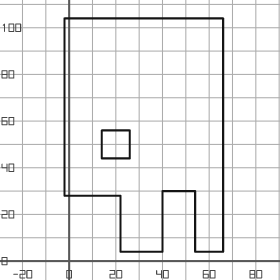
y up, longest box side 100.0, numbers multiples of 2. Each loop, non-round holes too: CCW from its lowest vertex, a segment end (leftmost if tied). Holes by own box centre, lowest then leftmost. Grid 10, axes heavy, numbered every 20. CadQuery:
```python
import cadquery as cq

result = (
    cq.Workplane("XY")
    .moveTo(22.0, 4.0)
    .lineTo(40.0, 4.0)
    .lineTo(40.0, 30.0)
    .lineTo(54.0, 30.0)
    .lineTo(54.0, 4.0)
    .lineTo(66.0, 4.0)
    .lineTo(66.0, 104.0)
    .lineTo(-2.0, 104.0)
    .lineTo(-2.0, 28.0)
    .lineTo(22.0, 28.0)
    .close()
    .moveTo(14.0, 44.0)
    .lineTo(26.0, 44.0)
    .lineTo(26.0, 56.0)
    .lineTo(14.0, 56.0)
    .close()
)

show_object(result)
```